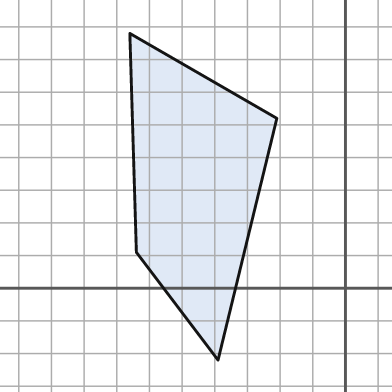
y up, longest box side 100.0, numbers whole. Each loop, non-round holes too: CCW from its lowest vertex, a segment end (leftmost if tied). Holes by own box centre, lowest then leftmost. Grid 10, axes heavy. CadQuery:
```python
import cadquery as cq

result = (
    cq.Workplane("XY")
    .moveTo(-39.0, -22.0)
    .lineTo(-21.0, 52.0)
    .lineTo(-66.0, 78.0)
    .lineTo(-64.0, 11.0)
    .close()
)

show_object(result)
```